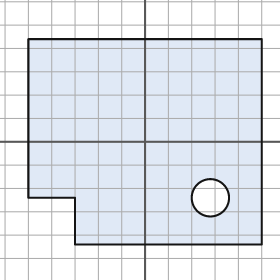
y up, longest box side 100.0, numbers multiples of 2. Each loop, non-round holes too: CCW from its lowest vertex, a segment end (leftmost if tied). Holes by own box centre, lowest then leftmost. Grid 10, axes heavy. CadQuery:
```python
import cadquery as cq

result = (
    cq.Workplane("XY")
    .moveTo(-30.0, -44.0)
    .lineTo(50.0, -44.0)
    .lineTo(50.0, 44.0)
    .lineTo(-50.0, 44.0)
    .lineTo(-50.0, -24.0)
    .lineTo(-30.0, -24.0)
    .close()
    .moveTo(28.0, -24.0)
    .circle(8.0)
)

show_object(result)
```